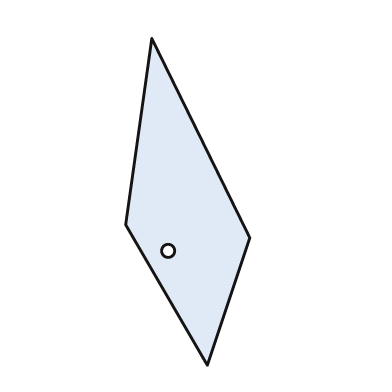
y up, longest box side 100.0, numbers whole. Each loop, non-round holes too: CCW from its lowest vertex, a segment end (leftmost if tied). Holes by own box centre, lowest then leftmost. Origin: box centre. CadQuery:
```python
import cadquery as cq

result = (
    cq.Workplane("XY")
    .moveTo(6.0, -50.0)
    .lineTo(19.0, -11.0)
    .lineTo(-11.0, 50.0)
    .lineTo(-19.0, -7.0)
    .close()
    .moveTo(-6.0, -15.0)
    .circle(2.0)
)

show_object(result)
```